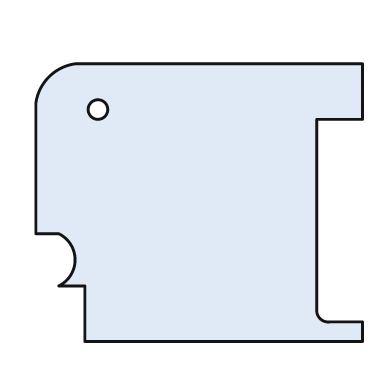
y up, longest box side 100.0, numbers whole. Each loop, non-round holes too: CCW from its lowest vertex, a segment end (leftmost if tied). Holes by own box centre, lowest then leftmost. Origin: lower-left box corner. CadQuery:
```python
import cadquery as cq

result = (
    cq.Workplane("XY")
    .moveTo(15.0, 0.0)
    .lineTo(100.0, 0.0)
    .lineTo(100.0, 6.0)
    .lineTo(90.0, 6.0)
    .threePointArc((87.0, 7.0), (86.0, 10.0))
    .lineTo(86.0, 68.0)
    .lineTo(100.0, 68.0)
    .lineTo(100.0, 85.0)
    .lineTo(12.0, 85.0)
    .threePointArc((4.0, 81.0), (0.0, 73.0))
    .lineTo(0.0, 33.0)
    .lineTo(7.0, 33.0)
    .threePointArc((12.0, 25.0), (7.0, 17.0))
    .lineTo(15.0, 17.0)
    .close()
    .moveTo(19.0, 71.0)
    .circle(3.0)
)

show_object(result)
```